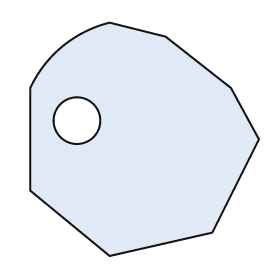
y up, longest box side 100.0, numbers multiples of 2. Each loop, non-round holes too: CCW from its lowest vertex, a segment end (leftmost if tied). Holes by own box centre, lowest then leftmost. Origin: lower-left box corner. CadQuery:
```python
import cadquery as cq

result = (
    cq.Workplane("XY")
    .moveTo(34.0, 0.0)
    .lineTo(78.0, 10.0)
    .lineTo(98.0, 50.0)
    .lineTo(86.0, 72.0)
    .lineTo(58.0, 94.0)
    .lineTo(34.0, 100.0)
    .threePointArc((14.0, 90.0), (0.0, 72.0))
    .lineTo(0.0, 28.0)
    .close()
    .moveTo(20.0, 58.0)
    .circle(10.0)
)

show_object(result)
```